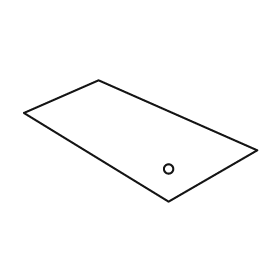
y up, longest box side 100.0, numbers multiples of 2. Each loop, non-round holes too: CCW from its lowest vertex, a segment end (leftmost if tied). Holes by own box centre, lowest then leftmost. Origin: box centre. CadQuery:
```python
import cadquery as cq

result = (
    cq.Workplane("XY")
    .moveTo(12.0, -26.0)
    .lineTo(50.0, -4.0)
    .lineTo(-18.0, 26.0)
    .lineTo(-50.0, 12.0)
    .close()
    .moveTo(12.0, -12.0)
    .circle(2.0)
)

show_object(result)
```